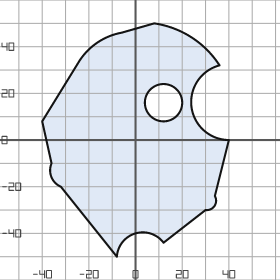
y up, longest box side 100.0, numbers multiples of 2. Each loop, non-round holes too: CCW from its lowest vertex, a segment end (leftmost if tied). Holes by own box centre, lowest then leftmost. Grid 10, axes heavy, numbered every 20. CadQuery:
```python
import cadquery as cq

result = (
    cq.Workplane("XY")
    .moveTo(-8.0, -50.0)
    .threePointArc((0.0, -40.0), (12.0, -44.0))
    .lineTo(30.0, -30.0)
    .threePointArc((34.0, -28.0), (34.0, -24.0))
    .lineTo(40.0, 0.0)
    .threePointArc((24.0, 14.0), (36.0, 32.0))
    .threePointArc((24.0, 44.0), (8.0, 50.0))
    .lineTo(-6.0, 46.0)
    .threePointArc((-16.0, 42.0), (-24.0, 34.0))
    .lineTo(-40.0, 8.0)
    .lineTo(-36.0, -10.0)
    .threePointArc((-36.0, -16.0), (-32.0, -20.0))
    .close()
    .moveTo(12.0, 16.0)
    .circle(8.0)
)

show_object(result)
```